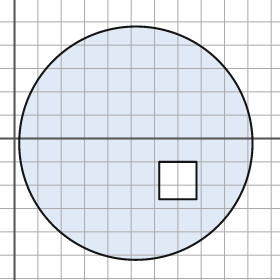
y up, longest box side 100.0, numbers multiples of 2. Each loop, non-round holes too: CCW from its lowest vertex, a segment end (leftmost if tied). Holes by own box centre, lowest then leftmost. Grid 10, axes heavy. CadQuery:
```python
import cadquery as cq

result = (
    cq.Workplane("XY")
    .moveTo(52.0, -2.0)
    .circle(50.0)
    .moveTo(62.0, -26.0)
    .lineTo(78.0, -26.0)
    .lineTo(78.0, -10.0)
    .lineTo(62.0, -10.0)
    .close()
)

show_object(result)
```